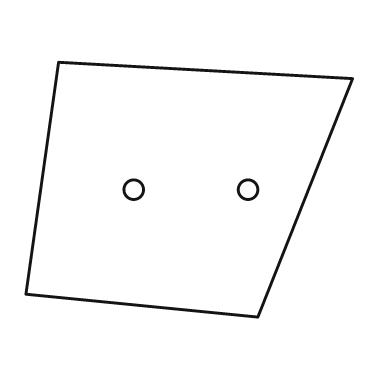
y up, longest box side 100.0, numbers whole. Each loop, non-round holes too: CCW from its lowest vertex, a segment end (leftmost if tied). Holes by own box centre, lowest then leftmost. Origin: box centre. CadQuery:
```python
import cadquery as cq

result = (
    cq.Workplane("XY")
    .moveTo(21.0, -39.0)
    .lineTo(50.0, 34.0)
    .lineTo(-40.0, 39.0)
    .lineTo(-50.0, -32.0)
    .close()
    .moveTo(-17.0, 0.0)
    .circle(3.0)
    .moveTo(18.0, 0.0)
    .circle(3.0)
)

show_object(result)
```